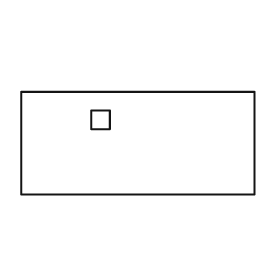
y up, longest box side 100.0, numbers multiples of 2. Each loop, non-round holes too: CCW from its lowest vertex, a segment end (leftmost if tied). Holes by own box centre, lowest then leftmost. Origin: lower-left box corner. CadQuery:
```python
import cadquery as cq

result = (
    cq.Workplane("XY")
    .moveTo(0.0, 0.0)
    .lineTo(100.0, 0.0)
    .lineTo(100.0, 44.0)
    .lineTo(0.0, 44.0)
    .close()
    .moveTo(30.0, 28.0)
    .lineTo(38.0, 28.0)
    .lineTo(38.0, 36.0)
    .lineTo(30.0, 36.0)
    .close()
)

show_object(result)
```